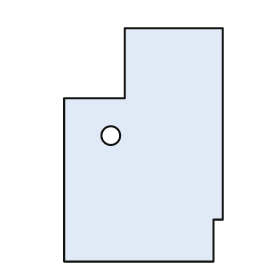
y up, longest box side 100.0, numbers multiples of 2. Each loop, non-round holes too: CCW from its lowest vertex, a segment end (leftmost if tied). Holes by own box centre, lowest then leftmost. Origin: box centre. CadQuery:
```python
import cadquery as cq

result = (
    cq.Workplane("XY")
    .moveTo(-34.0, -50.0)
    .lineTo(30.0, -50.0)
    .lineTo(30.0, -32.0)
    .lineTo(34.0, -32.0)
    .lineTo(34.0, 50.0)
    .lineTo(-8.0, 50.0)
    .lineTo(-8.0, 20.0)
    .lineTo(-34.0, 20.0)
    .close()
    .moveTo(-14.0, 4.0)
    .circle(4.0)
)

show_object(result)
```